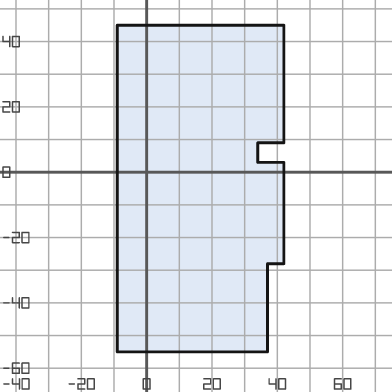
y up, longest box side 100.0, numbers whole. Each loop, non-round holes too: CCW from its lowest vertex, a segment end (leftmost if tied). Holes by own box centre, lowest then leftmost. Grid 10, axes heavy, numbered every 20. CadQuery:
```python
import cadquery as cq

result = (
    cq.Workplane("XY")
    .moveTo(-9.0, -55.0)
    .lineTo(37.0, -55.0)
    .lineTo(37.0, -28.0)
    .lineTo(42.0, -28.0)
    .lineTo(42.0, 3.0)
    .lineTo(34.0, 3.0)
    .lineTo(34.0, 9.0)
    .lineTo(42.0, 9.0)
    .lineTo(42.0, 45.0)
    .lineTo(-9.0, 45.0)
    .close()
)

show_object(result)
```